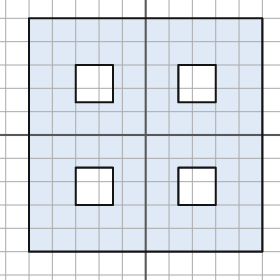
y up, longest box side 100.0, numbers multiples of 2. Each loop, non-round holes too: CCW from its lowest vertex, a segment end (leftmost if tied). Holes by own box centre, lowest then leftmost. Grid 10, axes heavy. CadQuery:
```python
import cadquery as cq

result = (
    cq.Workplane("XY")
    .moveTo(-50.0, -50.0)
    .lineTo(50.0, -50.0)
    .lineTo(50.0, 50.0)
    .lineTo(-50.0, 50.0)
    .close()
    .moveTo(-30.0, -30.0)
    .lineTo(-14.0, -30.0)
    .lineTo(-14.0, -14.0)
    .lineTo(-30.0, -14.0)
    .close()
    .moveTo(14.0, -30.0)
    .lineTo(30.0, -30.0)
    .lineTo(30.0, -14.0)
    .lineTo(14.0, -14.0)
    .close()
    .moveTo(-30.0, 14.0)
    .lineTo(-14.0, 14.0)
    .lineTo(-14.0, 30.0)
    .lineTo(-30.0, 30.0)
    .close()
    .moveTo(14.0, 14.0)
    .lineTo(30.0, 14.0)
    .lineTo(30.0, 30.0)
    .lineTo(14.0, 30.0)
    .close()
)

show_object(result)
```